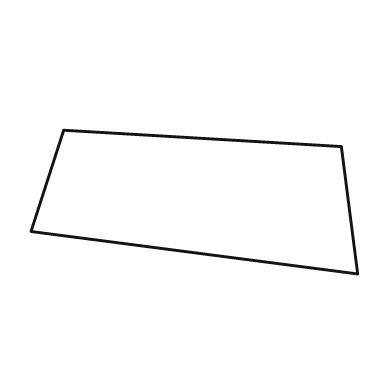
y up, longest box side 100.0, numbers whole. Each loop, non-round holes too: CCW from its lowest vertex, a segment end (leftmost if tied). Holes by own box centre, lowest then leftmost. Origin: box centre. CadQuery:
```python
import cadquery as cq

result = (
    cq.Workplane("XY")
    .moveTo(50.0, -22.0)
    .lineTo(45.0, 17.0)
    .lineTo(-40.0, 22.0)
    .lineTo(-50.0, -9.0)
    .close()
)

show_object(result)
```